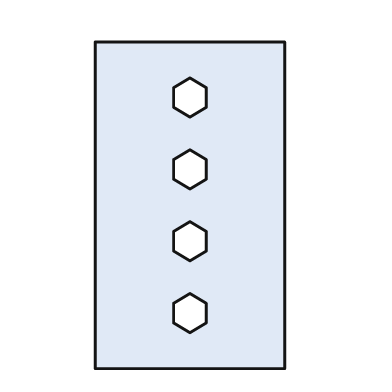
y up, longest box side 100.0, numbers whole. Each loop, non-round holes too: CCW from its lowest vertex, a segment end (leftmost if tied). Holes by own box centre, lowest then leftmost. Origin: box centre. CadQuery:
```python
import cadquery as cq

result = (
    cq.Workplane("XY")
    .moveTo(-29.0, -50.0)
    .lineTo(29.0, -50.0)
    .lineTo(29.0, 50.0)
    .lineTo(-29.0, 50.0)
    .close()
    .moveTo(0.0, -39.0)
    .lineTo(5.0, -36.0)
    .lineTo(5.0, -30.0)
    .lineTo(0.0, -27.0)
    .lineTo(-5.0, -30.0)
    .lineTo(-5.0, -36.0)
    .close()
    .moveTo(0.0, -17.0)
    .lineTo(5.0, -14.0)
    .lineTo(5.0, -8.0)
    .lineTo(0.0, -5.0)
    .lineTo(-5.0, -8.0)
    .lineTo(-5.0, -14.0)
    .close()
    .moveTo(0.0, 5.0)
    .lineTo(5.0, 8.0)
    .lineTo(5.0, 14.0)
    .lineTo(0.0, 17.0)
    .lineTo(-5.0, 14.0)
    .lineTo(-5.0, 8.0)
    .close()
    .moveTo(0.0, 27.0)
    .lineTo(5.0, 30.0)
    .lineTo(5.0, 36.0)
    .lineTo(0.0, 39.0)
    .lineTo(-5.0, 36.0)
    .lineTo(-5.0, 30.0)
    .close()
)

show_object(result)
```